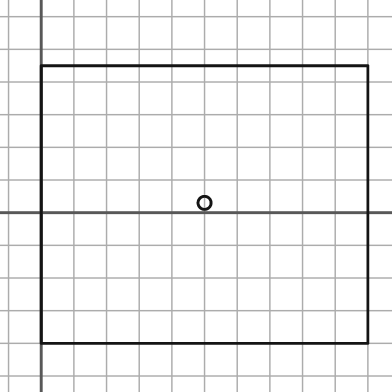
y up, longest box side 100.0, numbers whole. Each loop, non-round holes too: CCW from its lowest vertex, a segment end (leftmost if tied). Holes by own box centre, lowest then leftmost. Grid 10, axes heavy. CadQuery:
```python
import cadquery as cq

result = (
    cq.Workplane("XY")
    .moveTo(0.0, -40.0)
    .lineTo(100.0, -40.0)
    .lineTo(100.0, 45.0)
    .lineTo(0.0, 45.0)
    .close()
    .moveTo(50.0, 3.0)
    .circle(2.0)
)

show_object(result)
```